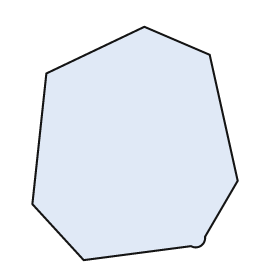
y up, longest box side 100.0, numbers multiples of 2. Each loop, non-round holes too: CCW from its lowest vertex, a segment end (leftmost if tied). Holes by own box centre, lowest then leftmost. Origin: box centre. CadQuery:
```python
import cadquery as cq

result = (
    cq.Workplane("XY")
    .moveTo(-22.0, -50.0)
    .lineTo(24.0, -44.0)
    .threePointArc((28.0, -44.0), (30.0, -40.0))
    .lineTo(44.0, -16.0)
    .lineTo(32.0, 38.0)
    .lineTo(4.0, 50.0)
    .lineTo(-38.0, 30.0)
    .lineTo(-44.0, -26.0)
    .close()
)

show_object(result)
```